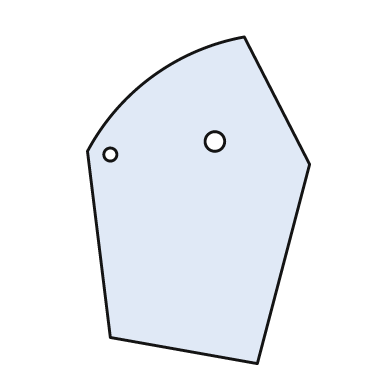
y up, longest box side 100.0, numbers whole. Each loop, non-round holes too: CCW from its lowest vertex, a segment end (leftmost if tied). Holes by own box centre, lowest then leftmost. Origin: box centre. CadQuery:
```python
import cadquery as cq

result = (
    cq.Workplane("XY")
    .moveTo(18.0, -50.0)
    .lineTo(34.0, 11.0)
    .lineTo(14.0, 50.0)
    .threePointArc((-14.0, 38.0), (-34.0, 15.0))
    .lineTo(-27.0, -42.0)
    .close()
    .moveTo(-27.0, 14.0)
    .circle(2.0)
    .moveTo(5.0, 18.0)
    .circle(3.0)
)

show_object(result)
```